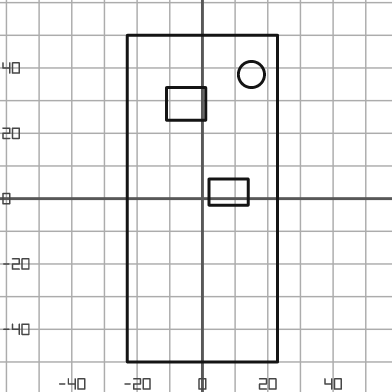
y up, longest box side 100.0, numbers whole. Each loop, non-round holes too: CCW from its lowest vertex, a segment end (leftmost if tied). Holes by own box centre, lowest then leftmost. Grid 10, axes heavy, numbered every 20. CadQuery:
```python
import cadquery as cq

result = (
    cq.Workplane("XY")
    .moveTo(-23.0, -50.0)
    .lineTo(23.0, -50.0)
    .lineTo(23.0, 50.0)
    .lineTo(-23.0, 50.0)
    .close()
    .moveTo(2.0, -2.0)
    .lineTo(14.0, -2.0)
    .lineTo(14.0, 6.0)
    .lineTo(2.0, 6.0)
    .close()
    .moveTo(-11.0, 24.0)
    .lineTo(1.0, 24.0)
    .lineTo(1.0, 34.0)
    .lineTo(-11.0, 34.0)
    .close()
    .moveTo(15.0, 38.0)
    .circle(4.0)
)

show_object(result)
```